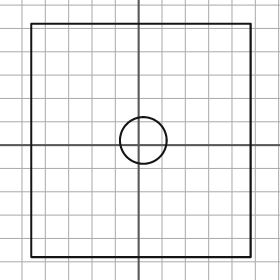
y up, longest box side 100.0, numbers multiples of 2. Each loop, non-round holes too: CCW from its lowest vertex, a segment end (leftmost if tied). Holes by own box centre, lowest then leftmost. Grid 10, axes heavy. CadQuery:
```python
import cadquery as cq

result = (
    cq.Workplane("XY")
    .moveTo(-46.0, -48.0)
    .lineTo(48.0, -48.0)
    .lineTo(48.0, 52.0)
    .lineTo(-46.0, 52.0)
    .close()
    .moveTo(2.0, 2.0)
    .circle(10.0)
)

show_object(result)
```